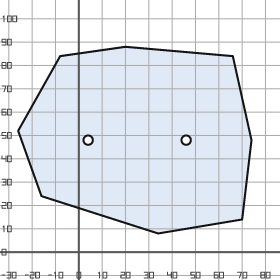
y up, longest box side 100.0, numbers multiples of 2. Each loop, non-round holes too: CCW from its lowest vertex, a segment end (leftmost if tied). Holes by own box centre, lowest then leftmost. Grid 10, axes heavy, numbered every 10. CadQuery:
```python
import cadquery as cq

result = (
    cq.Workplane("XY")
    .moveTo(34.0, 8.0)
    .lineTo(70.0, 14.0)
    .lineTo(74.0, 48.0)
    .lineTo(66.0, 84.0)
    .lineTo(20.0, 88.0)
    .lineTo(-8.0, 84.0)
    .lineTo(-26.0, 52.0)
    .lineTo(-16.0, 24.0)
    .close()
    .moveTo(4.0, 48.0)
    .circle(2.0)
    .moveTo(46.0, 48.0)
    .circle(2.0)
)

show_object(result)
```